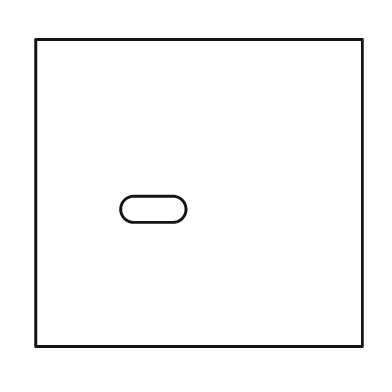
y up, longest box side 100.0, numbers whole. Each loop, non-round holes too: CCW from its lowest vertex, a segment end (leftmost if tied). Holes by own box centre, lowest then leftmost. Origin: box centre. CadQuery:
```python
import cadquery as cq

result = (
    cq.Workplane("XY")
    .moveTo(-50.0, -47.0)
    .lineTo(50.0, -47.0)
    .lineTo(50.0, 47.0)
    .lineTo(-50.0, 47.0)
    .close()
    .moveTo(-20.0, -9.0)
    .lineTo(-8.0, -9.0)
    .threePointArc((-4.0, -5.0), (-8.0, -1.0))
    .lineTo(-20.0, -1.0)
    .threePointArc((-24.0, -5.0), (-20.0, -9.0))
    .close()
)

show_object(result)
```